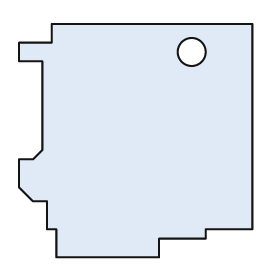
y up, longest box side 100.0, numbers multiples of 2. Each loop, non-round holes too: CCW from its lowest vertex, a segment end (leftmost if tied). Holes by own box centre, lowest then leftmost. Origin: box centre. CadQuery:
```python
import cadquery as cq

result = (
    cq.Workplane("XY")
    .moveTo(-34.0, -50.0)
    .lineTo(10.0, -50.0)
    .lineTo(10.0, -42.0)
    .lineTo(30.0, -42.0)
    .lineTo(30.0, -38.0)
    .lineTo(50.0, -38.0)
    .lineTo(50.0, 50.0)
    .lineTo(-36.0, 50.0)
    .lineTo(-36.0, 42.0)
    .lineTo(-50.0, 42.0)
    .lineTo(-50.0, 34.0)
    .lineTo(-40.0, 34.0)
    .lineTo(-40.0, -4.0)
    .lineTo(-44.0, -8.0)
    .lineTo(-50.0, -8.0)
    .lineTo(-50.0, -20.0)
    .lineTo(-44.0, -26.0)
    .lineTo(-38.0, -26.0)
    .lineTo(-38.0, -38.0)
    .lineTo(-34.0, -38.0)
    .close()
    .moveTo(24.0, 38.0)
    .circle(6.0)
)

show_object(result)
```